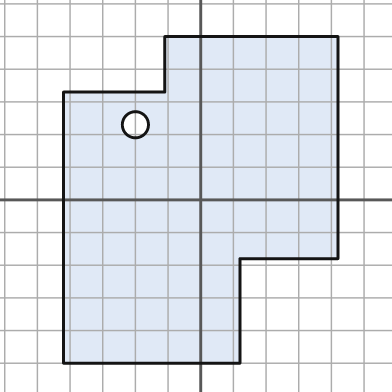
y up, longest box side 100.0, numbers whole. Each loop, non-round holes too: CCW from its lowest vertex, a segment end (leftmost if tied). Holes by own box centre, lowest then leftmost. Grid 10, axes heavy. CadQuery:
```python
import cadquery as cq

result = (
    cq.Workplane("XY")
    .moveTo(-42.0, -50.0)
    .lineTo(12.0, -50.0)
    .lineTo(12.0, -18.0)
    .lineTo(42.0, -18.0)
    .lineTo(42.0, 50.0)
    .lineTo(-11.0, 50.0)
    .lineTo(-11.0, 33.0)
    .lineTo(-42.0, 33.0)
    .close()
    .moveTo(-20.0, 23.0)
    .circle(4.0)
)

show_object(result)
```